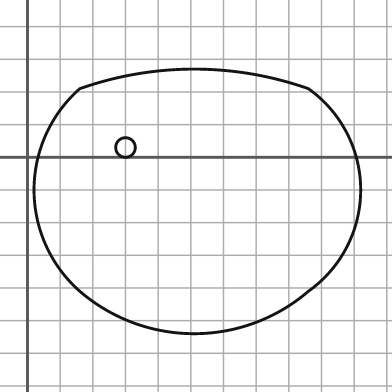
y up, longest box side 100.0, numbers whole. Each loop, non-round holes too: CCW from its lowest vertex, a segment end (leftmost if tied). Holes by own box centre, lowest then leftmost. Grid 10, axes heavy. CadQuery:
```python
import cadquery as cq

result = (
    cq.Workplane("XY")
    .moveTo(16.0, -41.0)
    .threePointArc((51.0, -54.0), (86.0, -41.0))
    .threePointArc((102.0, -10.0), (86.0, 21.0))
    .threePointArc((51.0, 27.0), (16.0, 21.0))
    .threePointArc((2.0, -10.0), (16.0, -41.0))
    .close()
    .moveTo(30.0, 3.0)
    .circle(3.0)
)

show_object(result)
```